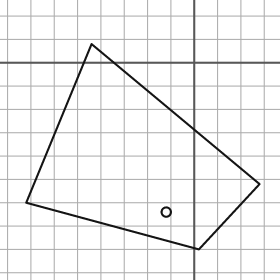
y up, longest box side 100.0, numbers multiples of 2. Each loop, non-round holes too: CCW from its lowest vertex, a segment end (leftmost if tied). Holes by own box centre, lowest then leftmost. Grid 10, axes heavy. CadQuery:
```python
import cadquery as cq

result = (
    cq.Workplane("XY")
    .moveTo(2.0, -80.0)
    .lineTo(28.0, -52.0)
    .lineTo(-44.0, 8.0)
    .lineTo(-72.0, -60.0)
    .close()
    .moveTo(-12.0, -64.0)
    .circle(2.0)
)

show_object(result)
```